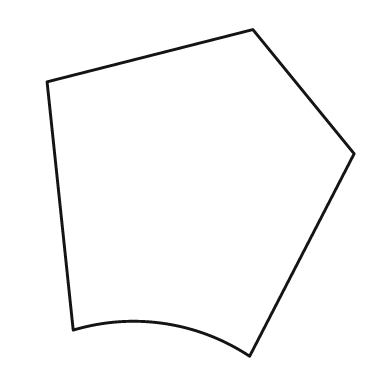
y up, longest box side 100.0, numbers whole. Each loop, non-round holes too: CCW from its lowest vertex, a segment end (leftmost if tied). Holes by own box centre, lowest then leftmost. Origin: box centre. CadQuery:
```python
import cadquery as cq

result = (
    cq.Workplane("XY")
    .moveTo(15.0, -50.0)
    .lineTo(47.0, 12.0)
    .lineTo(16.0, 50.0)
    .lineTo(-47.0, 34.0)
    .lineTo(-39.0, -42.0)
    .threePointArc((-11.0, -40.0), (15.0, -50.0))
    .close()
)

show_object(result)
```